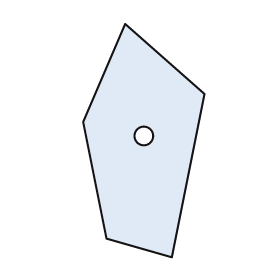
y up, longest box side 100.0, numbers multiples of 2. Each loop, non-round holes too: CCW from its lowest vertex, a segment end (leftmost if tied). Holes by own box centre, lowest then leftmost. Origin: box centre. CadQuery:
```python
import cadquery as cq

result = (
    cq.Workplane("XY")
    .moveTo(12.0, -50.0)
    .lineTo(26.0, 20.0)
    .lineTo(-8.0, 50.0)
    .lineTo(-26.0, 8.0)
    .lineTo(-16.0, -42.0)
    .close()
    .moveTo(0.0, 2.0)
    .circle(4.0)
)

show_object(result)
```